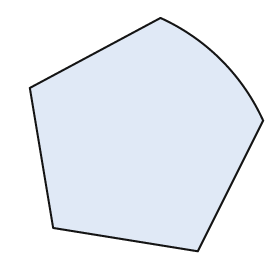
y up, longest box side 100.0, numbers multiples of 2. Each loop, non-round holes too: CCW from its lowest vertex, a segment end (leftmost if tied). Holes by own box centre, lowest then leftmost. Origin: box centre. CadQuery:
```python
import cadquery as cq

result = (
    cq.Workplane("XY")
    .moveTo(22.0, -50.0)
    .lineTo(50.0, 6.0)
    .threePointArc((32.0, 32.0), (6.0, 50.0))
    .lineTo(-50.0, 20.0)
    .lineTo(-40.0, -40.0)
    .close()
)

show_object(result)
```